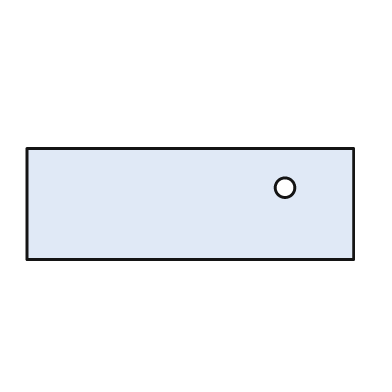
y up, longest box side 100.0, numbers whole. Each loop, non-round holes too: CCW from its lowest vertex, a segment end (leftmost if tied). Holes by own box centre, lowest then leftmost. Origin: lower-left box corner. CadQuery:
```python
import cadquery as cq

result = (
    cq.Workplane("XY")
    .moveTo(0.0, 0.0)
    .lineTo(100.0, 0.0)
    .lineTo(100.0, 34.0)
    .lineTo(0.0, 34.0)
    .close()
    .moveTo(79.0, 22.0)
    .circle(3.0)
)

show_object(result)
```